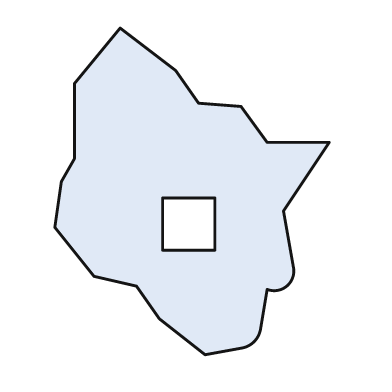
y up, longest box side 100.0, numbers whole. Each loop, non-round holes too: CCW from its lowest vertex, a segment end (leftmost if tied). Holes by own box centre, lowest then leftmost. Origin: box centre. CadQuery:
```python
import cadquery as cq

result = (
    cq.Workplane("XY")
    .moveTo(4.0, -50.0)
    .lineTo(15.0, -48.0)
    .threePointArc((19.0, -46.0), (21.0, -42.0))
    .lineTo(23.0, -30.0)
    .threePointArc((29.0, -29.0), (31.0, -23.0))
    .lineTo(28.0, -6.0)
    .lineTo(42.0, 15.0)
    .lineTo(23.0, 15.0)
    .lineTo(15.0, 26.0)
    .lineTo(2.0, 27.0)
    .lineTo(-5.0, 37.0)
    .lineTo(-22.0, 50.0)
    .lineTo(-36.0, 33.0)
    .lineTo(-36.0, 10.0)
    .lineTo(-40.0, 3.0)
    .lineTo(-42.0, -11.0)
    .lineTo(-30.0, -26.0)
    .lineTo(-17.0, -29.0)
    .lineTo(-10.0, -39.0)
    .close()
    .moveTo(-9.0, -18.0)
    .lineTo(7.0, -18.0)
    .lineTo(7.0, -2.0)
    .lineTo(-9.0, -2.0)
    .close()
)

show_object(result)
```